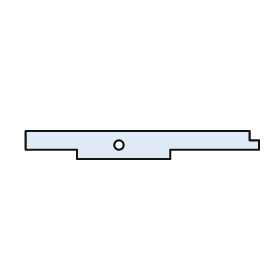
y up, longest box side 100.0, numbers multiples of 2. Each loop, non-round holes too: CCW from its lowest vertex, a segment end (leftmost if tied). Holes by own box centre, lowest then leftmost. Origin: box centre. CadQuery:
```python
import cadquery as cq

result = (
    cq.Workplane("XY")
    .moveTo(-28.0, -6.0)
    .lineTo(12.0, -6.0)
    .lineTo(12.0, -2.0)
    .lineTo(50.0, -2.0)
    .lineTo(50.0, 2.0)
    .lineTo(46.0, 2.0)
    .lineTo(46.0, 6.0)
    .lineTo(-50.0, 6.0)
    .lineTo(-50.0, -2.0)
    .lineTo(-28.0, -2.0)
    .close()
    .moveTo(-10.0, 0.0)
    .circle(2.0)
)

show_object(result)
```